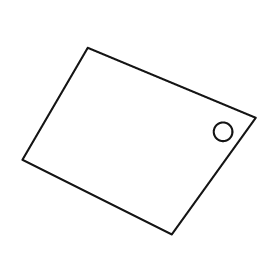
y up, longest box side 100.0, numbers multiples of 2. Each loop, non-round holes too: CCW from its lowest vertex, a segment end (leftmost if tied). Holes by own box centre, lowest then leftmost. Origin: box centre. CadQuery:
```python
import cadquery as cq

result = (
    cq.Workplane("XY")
    .moveTo(14.0, -40.0)
    .lineTo(50.0, 10.0)
    .lineTo(-22.0, 40.0)
    .lineTo(-50.0, -8.0)
    .close()
    .moveTo(36.0, 4.0)
    .circle(4.0)
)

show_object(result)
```